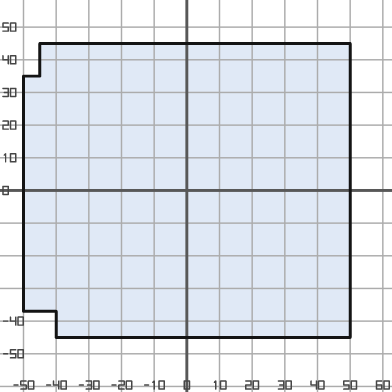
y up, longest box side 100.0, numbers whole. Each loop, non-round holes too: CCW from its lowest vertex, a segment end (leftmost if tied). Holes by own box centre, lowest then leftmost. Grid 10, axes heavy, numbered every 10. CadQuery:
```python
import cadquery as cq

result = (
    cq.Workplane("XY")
    .moveTo(-40.0, -45.0)
    .lineTo(50.0, -45.0)
    .lineTo(50.0, 45.0)
    .lineTo(-45.0, 45.0)
    .lineTo(-45.0, 35.0)
    .lineTo(-50.0, 35.0)
    .lineTo(-50.0, -37.0)
    .lineTo(-40.0, -37.0)
    .close()
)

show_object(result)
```